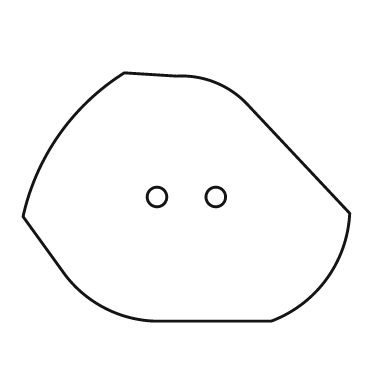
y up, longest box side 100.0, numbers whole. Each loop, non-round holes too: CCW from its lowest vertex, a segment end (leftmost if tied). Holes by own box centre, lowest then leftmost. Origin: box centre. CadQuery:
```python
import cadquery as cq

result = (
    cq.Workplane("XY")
    .moveTo(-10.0, -38.0)
    .lineTo(26.0, -38.0)
    .threePointArc((43.0, -25.0), (50.0, -5.0))
    .lineTo(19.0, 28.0)
    .threePointArc((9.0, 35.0), (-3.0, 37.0))
    .lineTo(-19.0, 38.0)
    .threePointArc((-39.0, 19.0), (-50.0, -6.0))
    .lineTo(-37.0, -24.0)
    .threePointArc((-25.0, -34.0), (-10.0, -38.0))
    .close()
    .moveTo(-9.0, 0.0)
    .circle(3.0)
    .moveTo(9.0, 0.0)
    .circle(3.0)
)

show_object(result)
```